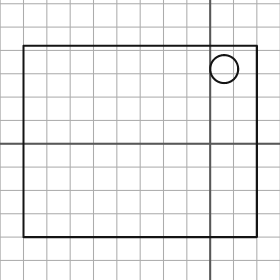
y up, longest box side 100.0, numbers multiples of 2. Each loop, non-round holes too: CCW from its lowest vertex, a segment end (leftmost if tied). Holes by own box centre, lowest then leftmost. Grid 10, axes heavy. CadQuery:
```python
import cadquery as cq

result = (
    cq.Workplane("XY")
    .moveTo(-80.0, -40.0)
    .lineTo(20.0, -40.0)
    .lineTo(20.0, 42.0)
    .lineTo(-80.0, 42.0)
    .close()
    .moveTo(6.0, 32.0)
    .circle(6.0)
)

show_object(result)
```